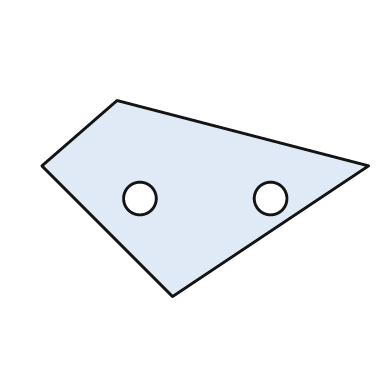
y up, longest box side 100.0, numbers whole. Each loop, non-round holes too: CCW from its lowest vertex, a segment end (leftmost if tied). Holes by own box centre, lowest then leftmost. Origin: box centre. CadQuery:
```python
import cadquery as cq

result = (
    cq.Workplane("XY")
    .moveTo(-10.0, -30.0)
    .lineTo(50.0, 10.0)
    .lineTo(-27.0, 30.0)
    .lineTo(-50.0, 10.0)
    .close()
    .moveTo(-20.0, 0.0)
    .circle(5.0)
    .moveTo(20.0, 0.0)
    .circle(5.0)
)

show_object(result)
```